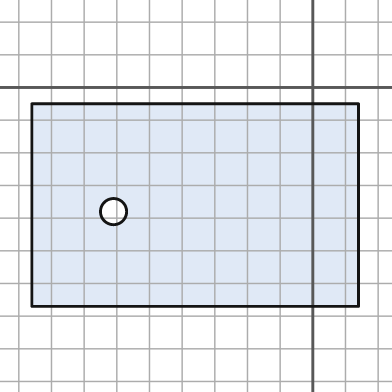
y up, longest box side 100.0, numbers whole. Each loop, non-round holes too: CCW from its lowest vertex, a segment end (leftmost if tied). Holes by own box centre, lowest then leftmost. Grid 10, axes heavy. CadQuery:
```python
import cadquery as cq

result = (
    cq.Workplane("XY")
    .moveTo(-86.0, -67.0)
    .lineTo(14.0, -67.0)
    .lineTo(14.0, -5.0)
    .lineTo(-86.0, -5.0)
    .close()
    .moveTo(-61.0, -38.0)
    .circle(4.0)
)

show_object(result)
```